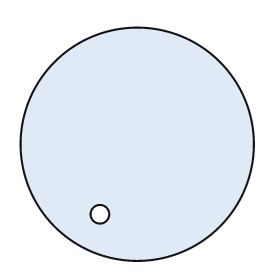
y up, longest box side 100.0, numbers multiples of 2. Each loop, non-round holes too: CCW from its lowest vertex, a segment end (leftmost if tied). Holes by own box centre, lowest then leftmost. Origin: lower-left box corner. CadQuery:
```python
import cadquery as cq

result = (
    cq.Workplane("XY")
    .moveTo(50.0, 50.0)
    .circle(50.0)
    .moveTo(34.0, 20.0)
    .circle(4.0)
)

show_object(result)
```